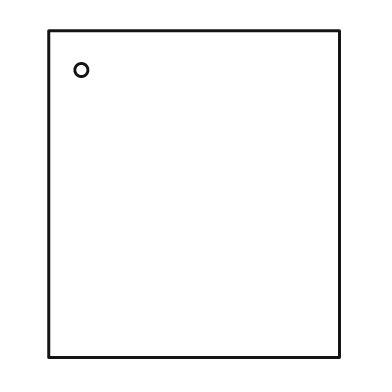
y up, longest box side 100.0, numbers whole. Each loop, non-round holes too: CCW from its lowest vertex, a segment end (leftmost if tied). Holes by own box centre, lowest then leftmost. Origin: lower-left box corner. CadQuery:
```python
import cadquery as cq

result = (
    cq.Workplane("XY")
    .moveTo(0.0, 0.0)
    .lineTo(89.0, 0.0)
    .lineTo(89.0, 100.0)
    .lineTo(0.0, 100.0)
    .close()
    .moveTo(10.0, 88.0)
    .circle(2.0)
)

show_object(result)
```